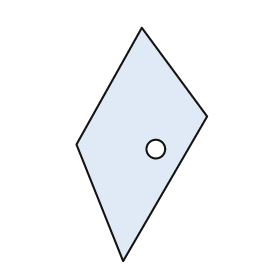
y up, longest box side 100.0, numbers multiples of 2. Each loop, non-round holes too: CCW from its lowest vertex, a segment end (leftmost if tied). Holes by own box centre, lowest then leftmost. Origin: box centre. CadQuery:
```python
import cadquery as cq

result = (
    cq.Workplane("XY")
    .moveTo(-8.0, -50.0)
    .lineTo(28.0, 12.0)
    .lineTo(0.0, 50.0)
    .lineTo(-28.0, 0.0)
    .close()
    .moveTo(6.0, -2.0)
    .circle(4.0)
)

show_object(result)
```